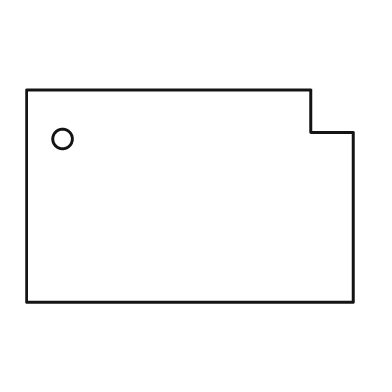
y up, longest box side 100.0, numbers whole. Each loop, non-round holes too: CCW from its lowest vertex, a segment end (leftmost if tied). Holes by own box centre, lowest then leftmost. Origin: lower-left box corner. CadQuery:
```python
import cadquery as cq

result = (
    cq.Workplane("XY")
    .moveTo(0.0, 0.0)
    .lineTo(100.0, 0.0)
    .lineTo(100.0, 52.0)
    .lineTo(87.0, 52.0)
    .lineTo(87.0, 65.0)
    .lineTo(0.0, 65.0)
    .close()
    .moveTo(11.0, 50.0)
    .circle(3.0)
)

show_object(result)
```